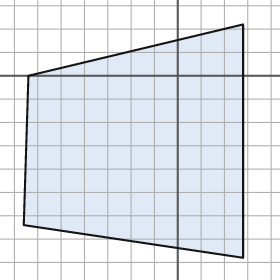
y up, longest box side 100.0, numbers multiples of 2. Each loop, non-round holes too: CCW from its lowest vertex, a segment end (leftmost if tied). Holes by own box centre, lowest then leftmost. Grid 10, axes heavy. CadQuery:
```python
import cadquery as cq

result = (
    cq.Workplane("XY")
    .moveTo(28.0, -78.0)
    .lineTo(28.0, 22.0)
    .lineTo(-64.0, 0.0)
    .lineTo(-66.0, -64.0)
    .close()
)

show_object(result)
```